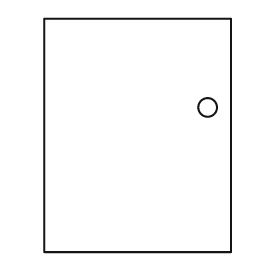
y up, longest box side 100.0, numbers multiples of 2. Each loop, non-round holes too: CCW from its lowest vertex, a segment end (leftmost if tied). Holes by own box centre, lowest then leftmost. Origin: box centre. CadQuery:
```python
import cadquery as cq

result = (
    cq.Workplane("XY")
    .moveTo(-40.0, -50.0)
    .lineTo(40.0, -50.0)
    .lineTo(40.0, 50.0)
    .lineTo(-40.0, 50.0)
    .close()
    .moveTo(30.0, 12.0)
    .circle(4.0)
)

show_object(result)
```